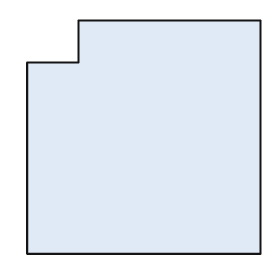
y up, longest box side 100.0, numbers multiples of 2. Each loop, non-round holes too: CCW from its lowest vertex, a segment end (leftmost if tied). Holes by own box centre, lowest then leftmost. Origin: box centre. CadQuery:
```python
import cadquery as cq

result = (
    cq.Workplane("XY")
    .moveTo(-50.0, -50.0)
    .lineTo(50.0, -50.0)
    .lineTo(50.0, 50.0)
    .lineTo(-28.0, 50.0)
    .lineTo(-28.0, 32.0)
    .lineTo(-50.0, 32.0)
    .close()
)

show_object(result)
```